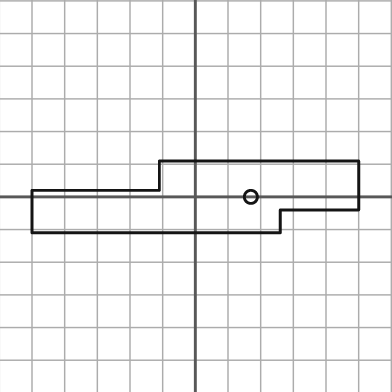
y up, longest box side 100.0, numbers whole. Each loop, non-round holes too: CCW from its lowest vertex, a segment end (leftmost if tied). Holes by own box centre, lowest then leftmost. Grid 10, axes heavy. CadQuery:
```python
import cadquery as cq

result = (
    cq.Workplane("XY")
    .moveTo(-50.0, -11.0)
    .lineTo(26.0, -11.0)
    .lineTo(26.0, -4.0)
    .lineTo(50.0, -4.0)
    .lineTo(50.0, 11.0)
    .lineTo(-11.0, 11.0)
    .lineTo(-11.0, 2.0)
    .lineTo(-50.0, 2.0)
    .close()
    .moveTo(17.0, 0.0)
    .circle(2.0)
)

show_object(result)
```